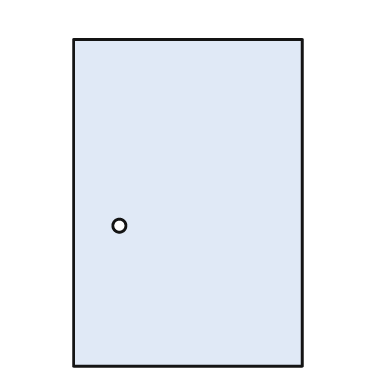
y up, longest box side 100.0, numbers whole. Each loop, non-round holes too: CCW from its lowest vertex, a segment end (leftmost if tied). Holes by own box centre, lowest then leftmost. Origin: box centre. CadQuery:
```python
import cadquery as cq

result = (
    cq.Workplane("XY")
    .moveTo(-35.0, -50.0)
    .lineTo(35.0, -50.0)
    .lineTo(35.0, 50.0)
    .lineTo(-35.0, 50.0)
    .close()
    .moveTo(-21.0, -7.0)
    .circle(2.0)
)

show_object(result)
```